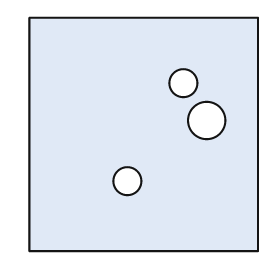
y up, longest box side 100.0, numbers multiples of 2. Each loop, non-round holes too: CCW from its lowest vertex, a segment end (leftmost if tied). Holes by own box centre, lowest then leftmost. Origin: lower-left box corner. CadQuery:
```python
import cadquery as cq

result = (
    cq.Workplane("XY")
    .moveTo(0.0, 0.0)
    .lineTo(98.0, 0.0)
    .lineTo(98.0, 100.0)
    .lineTo(0.0, 100.0)
    .close()
    .moveTo(42.0, 30.0)
    .circle(6.0)
    .moveTo(76.0, 56.0)
    .circle(8.0)
    .moveTo(66.0, 72.0)
    .circle(6.0)
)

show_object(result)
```